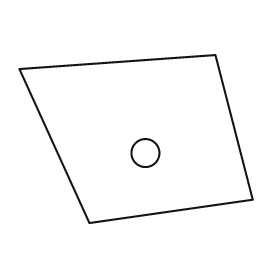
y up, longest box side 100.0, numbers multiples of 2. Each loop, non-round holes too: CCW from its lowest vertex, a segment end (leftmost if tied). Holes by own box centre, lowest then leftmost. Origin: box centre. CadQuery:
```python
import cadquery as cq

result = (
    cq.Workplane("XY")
    .moveTo(-20.0, -36.0)
    .lineTo(50.0, -26.0)
    .lineTo(34.0, 36.0)
    .lineTo(-50.0, 30.0)
    .close()
    .moveTo(4.0, -6.0)
    .circle(6.0)
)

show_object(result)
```